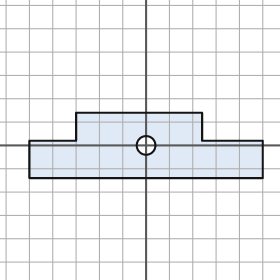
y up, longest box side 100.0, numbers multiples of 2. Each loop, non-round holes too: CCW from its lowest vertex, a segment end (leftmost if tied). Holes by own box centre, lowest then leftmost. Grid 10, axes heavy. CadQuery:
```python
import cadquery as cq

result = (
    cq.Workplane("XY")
    .moveTo(-50.0, -14.0)
    .lineTo(50.0, -14.0)
    .lineTo(50.0, 2.0)
    .lineTo(24.0, 2.0)
    .lineTo(24.0, 14.0)
    .lineTo(-30.0, 14.0)
    .lineTo(-30.0, 2.0)
    .lineTo(-50.0, 2.0)
    .close()
    .moveTo(0.0, 0.0)
    .circle(4.0)
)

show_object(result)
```